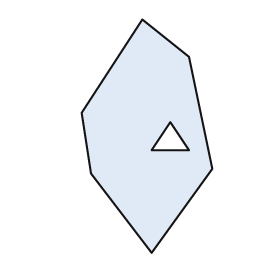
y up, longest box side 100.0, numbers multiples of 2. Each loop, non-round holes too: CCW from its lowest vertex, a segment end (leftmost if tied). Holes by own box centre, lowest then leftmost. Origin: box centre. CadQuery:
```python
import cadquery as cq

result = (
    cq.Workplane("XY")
    .moveTo(2.0, -50.0)
    .lineTo(28.0, -14.0)
    .lineTo(18.0, 34.0)
    .lineTo(-2.0, 50.0)
    .lineTo(-28.0, 10.0)
    .lineTo(-24.0, -16.0)
    .close()
    .moveTo(2.0, -6.0)
    .lineTo(18.0, -6.0)
    .lineTo(10.0, 6.0)
    .close()
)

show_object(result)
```